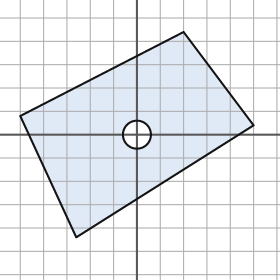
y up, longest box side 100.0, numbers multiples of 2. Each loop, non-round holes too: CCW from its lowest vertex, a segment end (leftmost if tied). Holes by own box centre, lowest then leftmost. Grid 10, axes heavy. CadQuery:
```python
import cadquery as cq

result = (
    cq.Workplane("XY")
    .moveTo(-26.0, -44.0)
    .lineTo(50.0, 4.0)
    .lineTo(20.0, 44.0)
    .lineTo(-50.0, 8.0)
    .close()
    .moveTo(0.0, 0.0)
    .circle(6.0)
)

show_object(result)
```